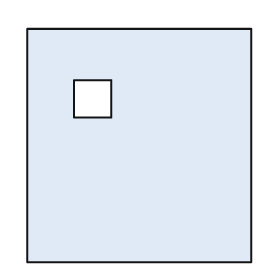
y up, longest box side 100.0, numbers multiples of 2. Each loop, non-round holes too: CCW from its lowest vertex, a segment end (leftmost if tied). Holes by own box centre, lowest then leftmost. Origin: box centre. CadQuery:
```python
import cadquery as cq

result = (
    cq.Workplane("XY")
    .moveTo(-48.0, -50.0)
    .lineTo(48.0, -50.0)
    .lineTo(48.0, 50.0)
    .lineTo(-48.0, 50.0)
    .close()
    .moveTo(-28.0, 12.0)
    .lineTo(-12.0, 12.0)
    .lineTo(-12.0, 28.0)
    .lineTo(-28.0, 28.0)
    .close()
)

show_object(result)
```